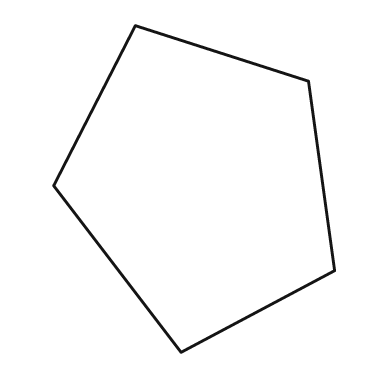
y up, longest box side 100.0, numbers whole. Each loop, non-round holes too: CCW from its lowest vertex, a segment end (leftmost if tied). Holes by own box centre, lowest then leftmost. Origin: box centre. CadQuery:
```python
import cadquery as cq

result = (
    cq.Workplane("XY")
    .moveTo(-4.0, -50.0)
    .lineTo(43.0, -25.0)
    .lineTo(35.0, 33.0)
    .lineTo(-18.0, 50.0)
    .lineTo(-43.0, 1.0)
    .close()
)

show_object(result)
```